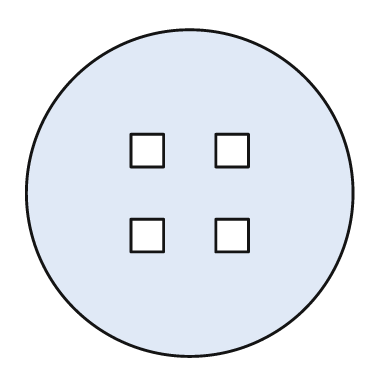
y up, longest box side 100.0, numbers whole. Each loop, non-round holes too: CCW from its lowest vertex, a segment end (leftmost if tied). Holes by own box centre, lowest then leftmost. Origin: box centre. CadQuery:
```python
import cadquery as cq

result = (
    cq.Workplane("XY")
    .moveTo(0.0, 0.0)
    .circle(50.0)
    .moveTo(-18.0, -18.0)
    .lineTo(-8.0, -18.0)
    .lineTo(-8.0, -8.0)
    .lineTo(-18.0, -8.0)
    .close()
    .moveTo(8.0, -18.0)
    .lineTo(18.0, -18.0)
    .lineTo(18.0, -8.0)
    .lineTo(8.0, -8.0)
    .close()
    .moveTo(-18.0, 8.0)
    .lineTo(-8.0, 8.0)
    .lineTo(-8.0, 18.0)
    .lineTo(-18.0, 18.0)
    .close()
    .moveTo(8.0, 8.0)
    .lineTo(18.0, 8.0)
    .lineTo(18.0, 18.0)
    .lineTo(8.0, 18.0)
    .close()
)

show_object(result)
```